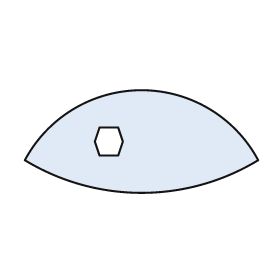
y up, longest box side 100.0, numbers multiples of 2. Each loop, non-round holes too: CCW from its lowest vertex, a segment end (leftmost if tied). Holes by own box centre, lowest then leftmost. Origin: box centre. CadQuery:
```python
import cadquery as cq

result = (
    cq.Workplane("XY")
    .moveTo(-50.0, -8.0)
    .threePointArc((0.0, -22.0), (50.0, -8.0))
    .threePointArc((0.0, 22.0), (-50.0, -8.0))
    .close()
    .moveTo(-18.0, -6.0)
    .lineTo(-10.0, -6.0)
    .lineTo(-8.0, 0.0)
    .lineTo(-10.0, 6.0)
    .lineTo(-18.0, 6.0)
    .lineTo(-20.0, 0.0)
    .close()
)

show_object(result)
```